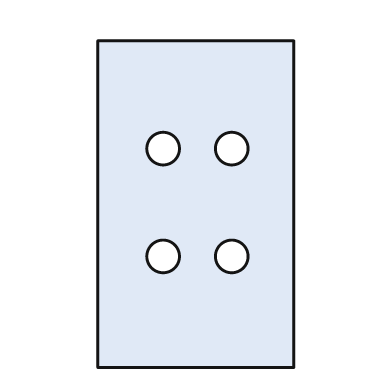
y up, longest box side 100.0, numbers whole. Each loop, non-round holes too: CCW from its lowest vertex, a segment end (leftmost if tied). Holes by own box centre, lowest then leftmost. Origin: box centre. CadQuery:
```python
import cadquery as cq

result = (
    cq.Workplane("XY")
    .moveTo(-30.0, -50.0)
    .lineTo(30.0, -50.0)
    .lineTo(30.0, 50.0)
    .lineTo(-30.0, 50.0)
    .close()
    .moveTo(-10.0, -16.0)
    .circle(5.0)
    .moveTo(11.0, -16.0)
    .circle(5.0)
    .moveTo(-10.0, 17.0)
    .circle(5.0)
    .moveTo(11.0, 17.0)
    .circle(5.0)
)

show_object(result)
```